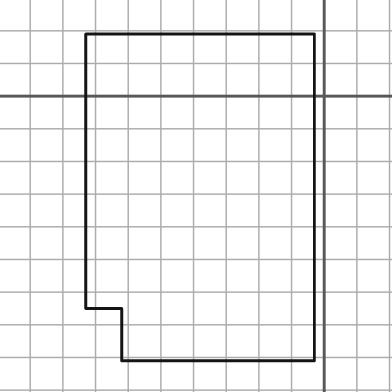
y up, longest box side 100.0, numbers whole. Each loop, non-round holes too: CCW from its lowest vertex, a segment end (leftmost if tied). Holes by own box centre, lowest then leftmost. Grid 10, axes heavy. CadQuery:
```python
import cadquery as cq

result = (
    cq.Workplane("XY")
    .moveTo(-62.0, -81.0)
    .lineTo(-3.0, -81.0)
    .lineTo(-3.0, 19.0)
    .lineTo(-73.0, 19.0)
    .lineTo(-73.0, -65.0)
    .lineTo(-62.0, -65.0)
    .close()
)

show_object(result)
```